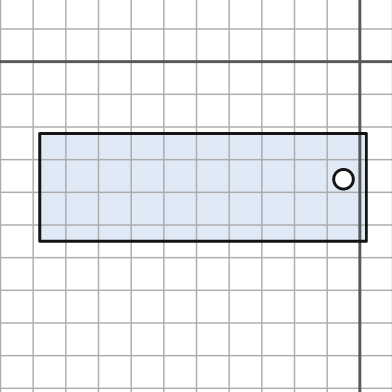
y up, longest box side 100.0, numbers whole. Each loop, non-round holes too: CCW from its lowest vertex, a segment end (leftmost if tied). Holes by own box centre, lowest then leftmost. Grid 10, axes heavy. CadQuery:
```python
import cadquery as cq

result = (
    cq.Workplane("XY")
    .moveTo(-98.0, -55.0)
    .lineTo(2.0, -55.0)
    .lineTo(2.0, -22.0)
    .lineTo(-98.0, -22.0)
    .close()
    .moveTo(-5.0, -36.0)
    .circle(3.0)
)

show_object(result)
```